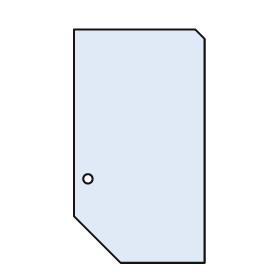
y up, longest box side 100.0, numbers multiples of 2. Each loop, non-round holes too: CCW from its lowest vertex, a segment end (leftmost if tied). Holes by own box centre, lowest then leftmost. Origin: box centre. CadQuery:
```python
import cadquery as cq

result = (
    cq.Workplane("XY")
    .moveTo(-8.0, -50.0)
    .lineTo(28.0, -50.0)
    .lineTo(28.0, 46.0)
    .lineTo(24.0, 50.0)
    .lineTo(-28.0, 50.0)
    .lineTo(-28.0, -30.0)
    .close()
    .moveTo(-22.0, -14.0)
    .circle(2.0)
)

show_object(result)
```